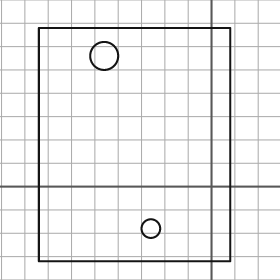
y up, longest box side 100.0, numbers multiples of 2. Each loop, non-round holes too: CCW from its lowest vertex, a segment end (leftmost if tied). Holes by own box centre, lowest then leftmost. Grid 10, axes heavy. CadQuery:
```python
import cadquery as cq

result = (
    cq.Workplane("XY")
    .moveTo(-74.0, -32.0)
    .lineTo(8.0, -32.0)
    .lineTo(8.0, 68.0)
    .lineTo(-74.0, 68.0)
    .close()
    .moveTo(-26.0, -18.0)
    .circle(4.0)
    .moveTo(-46.0, 56.0)
    .circle(6.0)
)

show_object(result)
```